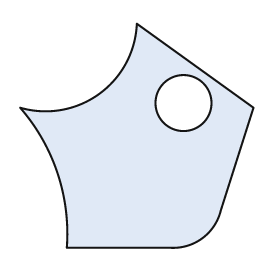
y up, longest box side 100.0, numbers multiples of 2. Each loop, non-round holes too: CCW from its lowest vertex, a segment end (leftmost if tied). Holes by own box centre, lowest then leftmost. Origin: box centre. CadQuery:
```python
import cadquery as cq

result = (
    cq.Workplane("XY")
    .moveTo(-30.0, -48.0)
    .lineTo(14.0, -48.0)
    .threePointArc((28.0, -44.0), (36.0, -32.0))
    .lineTo(50.0, 12.0)
    .lineTo(0.0, 48.0)
    .threePointArc((-16.0, 18.0), (-50.0, 12.0))
    .threePointArc((-34.0, -16.0), (-30.0, -48.0))
    .close()
    .moveTo(20.0, 14.0)
    .circle(12.0)
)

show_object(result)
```